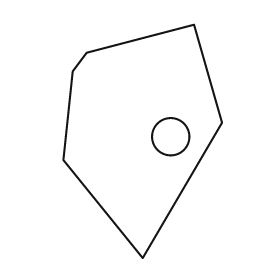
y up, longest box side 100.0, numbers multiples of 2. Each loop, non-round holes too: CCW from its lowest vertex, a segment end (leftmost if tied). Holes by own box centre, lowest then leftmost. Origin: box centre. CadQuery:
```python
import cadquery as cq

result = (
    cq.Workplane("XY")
    .moveTo(0.0, -50.0)
    .lineTo(34.0, 8.0)
    .lineTo(22.0, 50.0)
    .lineTo(-24.0, 38.0)
    .lineTo(-30.0, 30.0)
    .lineTo(-34.0, -8.0)
    .close()
    .moveTo(12.0, 2.0)
    .circle(8.0)
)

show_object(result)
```